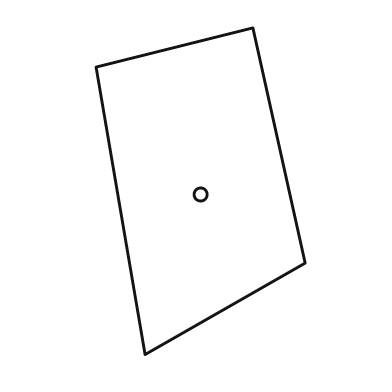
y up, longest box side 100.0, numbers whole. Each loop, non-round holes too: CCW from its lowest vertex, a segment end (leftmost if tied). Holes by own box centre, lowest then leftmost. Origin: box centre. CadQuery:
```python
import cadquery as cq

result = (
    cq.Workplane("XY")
    .moveTo(-17.0, -50.0)
    .lineTo(32.0, -22.0)
    .lineTo(16.0, 50.0)
    .lineTo(-32.0, 38.0)
    .close()
    .moveTo(0.0, -1.0)
    .circle(2.0)
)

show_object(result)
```